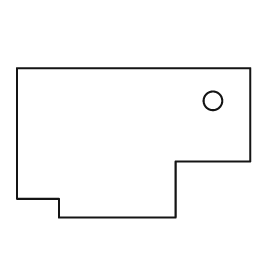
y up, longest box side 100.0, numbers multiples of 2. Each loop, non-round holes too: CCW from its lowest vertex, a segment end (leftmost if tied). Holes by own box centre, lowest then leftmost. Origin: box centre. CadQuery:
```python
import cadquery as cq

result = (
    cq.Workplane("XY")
    .moveTo(-32.0, -32.0)
    .lineTo(18.0, -32.0)
    .lineTo(18.0, -8.0)
    .lineTo(50.0, -8.0)
    .lineTo(50.0, 32.0)
    .lineTo(-50.0, 32.0)
    .lineTo(-50.0, -24.0)
    .lineTo(-32.0, -24.0)
    .close()
    .moveTo(34.0, 18.0)
    .circle(4.0)
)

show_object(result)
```